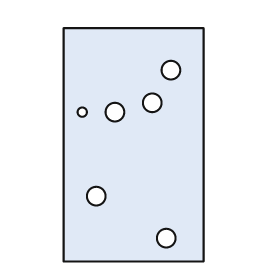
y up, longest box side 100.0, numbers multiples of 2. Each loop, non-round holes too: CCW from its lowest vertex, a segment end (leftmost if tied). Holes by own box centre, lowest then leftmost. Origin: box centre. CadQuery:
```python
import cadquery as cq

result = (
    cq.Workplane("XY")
    .moveTo(-30.0, -50.0)
    .lineTo(30.0, -50.0)
    .lineTo(30.0, 50.0)
    .lineTo(-30.0, 50.0)
    .close()
    .moveTo(14.0, -40.0)
    .circle(4.0)
    .moveTo(-16.0, -22.0)
    .circle(4.0)
    .moveTo(-22.0, 14.0)
    .circle(2.0)
    .moveTo(-8.0, 14.0)
    .circle(4.0)
    .moveTo(8.0, 18.0)
    .circle(4.0)
    .moveTo(16.0, 32.0)
    .circle(4.0)
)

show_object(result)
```